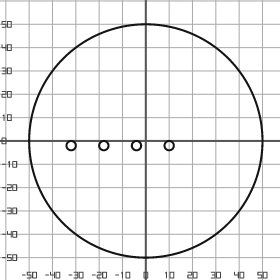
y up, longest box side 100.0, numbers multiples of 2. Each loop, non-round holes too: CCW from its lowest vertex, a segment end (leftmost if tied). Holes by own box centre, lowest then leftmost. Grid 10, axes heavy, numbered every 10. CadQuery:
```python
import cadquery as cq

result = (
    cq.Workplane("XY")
    .moveTo(0.0, 0.0)
    .circle(50.0)
    .moveTo(-32.0, -2.0)
    .circle(2.0)
    .moveTo(-18.0, -2.0)
    .circle(2.0)
    .moveTo(-4.0, -2.0)
    .circle(2.0)
    .moveTo(10.0, -2.0)
    .circle(2.0)
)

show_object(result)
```